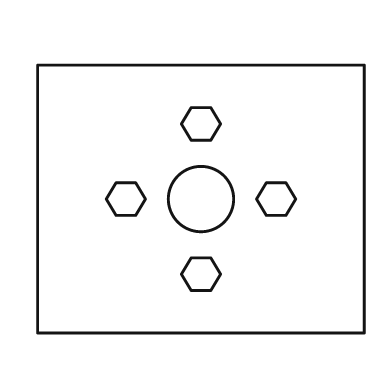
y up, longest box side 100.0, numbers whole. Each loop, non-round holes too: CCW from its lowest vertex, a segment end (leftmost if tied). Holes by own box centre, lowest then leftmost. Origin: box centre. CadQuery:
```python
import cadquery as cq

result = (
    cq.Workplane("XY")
    .moveTo(-50.0, -41.0)
    .lineTo(50.0, -41.0)
    .lineTo(50.0, 41.0)
    .lineTo(-50.0, 41.0)
    .close()
    .moveTo(-3.0, -28.0)
    .lineTo(3.0, -28.0)
    .lineTo(6.0, -23.0)
    .lineTo(3.0, -18.0)
    .lineTo(-3.0, -18.0)
    .lineTo(-6.0, -23.0)
    .close()
    .moveTo(-26.0, -5.0)
    .lineTo(-20.0, -5.0)
    .lineTo(-17.0, 0.0)
    .lineTo(-20.0, 5.0)
    .lineTo(-26.0, 5.0)
    .lineTo(-29.0, 0.0)
    .close()
    .moveTo(0.0, 0.0)
    .circle(10.0)
    .moveTo(20.0, -5.0)
    .lineTo(26.0, -5.0)
    .lineTo(29.0, 0.0)
    .lineTo(26.0, 5.0)
    .lineTo(20.0, 5.0)
    .lineTo(17.0, 0.0)
    .close()
    .moveTo(-3.0, 18.0)
    .lineTo(3.0, 18.0)
    .lineTo(6.0, 23.0)
    .lineTo(3.0, 28.0)
    .lineTo(-3.0, 28.0)
    .lineTo(-6.0, 23.0)
    .close()
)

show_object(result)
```